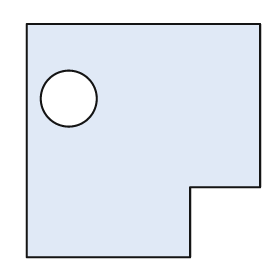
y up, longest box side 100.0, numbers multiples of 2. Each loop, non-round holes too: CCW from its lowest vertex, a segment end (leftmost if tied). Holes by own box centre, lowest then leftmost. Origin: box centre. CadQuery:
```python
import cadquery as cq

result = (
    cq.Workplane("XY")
    .moveTo(-50.0, -50.0)
    .lineTo(20.0, -50.0)
    .lineTo(20.0, -20.0)
    .lineTo(50.0, -20.0)
    .lineTo(50.0, 50.0)
    .lineTo(-50.0, 50.0)
    .close()
    .moveTo(-32.0, 18.0)
    .circle(12.0)
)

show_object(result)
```